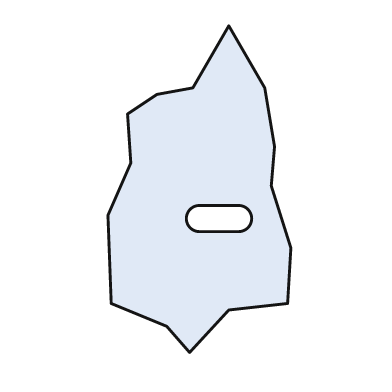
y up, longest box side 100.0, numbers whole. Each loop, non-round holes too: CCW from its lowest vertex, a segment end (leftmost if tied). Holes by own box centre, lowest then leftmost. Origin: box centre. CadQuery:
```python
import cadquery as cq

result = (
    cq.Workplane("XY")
    .moveTo(-3.0, -50.0)
    .lineTo(9.0, -37.0)
    .lineTo(27.0, -35.0)
    .lineTo(28.0, -18.0)
    .lineTo(22.0, 1.0)
    .lineTo(23.0, 13.0)
    .lineTo(20.0, 31.0)
    .lineTo(9.0, 50.0)
    .lineTo(-2.0, 31.0)
    .lineTo(-13.0, 29.0)
    .lineTo(-22.0, 23.0)
    .lineTo(-21.0, 8.0)
    .lineTo(-28.0, -8.0)
    .lineTo(-27.0, -35.0)
    .lineTo(-10.0, -42.0)
    .close()
    .moveTo(0.0, -13.0)
    .lineTo(12.0, -13.0)
    .threePointArc((16.0, -9.0), (12.0, -5.0))
    .lineTo(0.0, -5.0)
    .threePointArc((-4.0, -9.0), (0.0, -13.0))
    .close()
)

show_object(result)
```